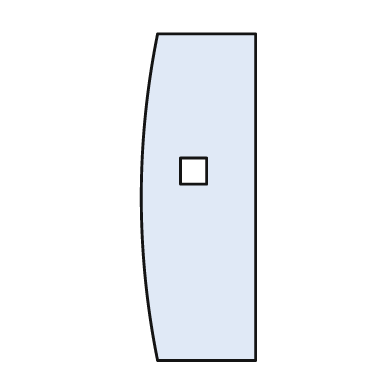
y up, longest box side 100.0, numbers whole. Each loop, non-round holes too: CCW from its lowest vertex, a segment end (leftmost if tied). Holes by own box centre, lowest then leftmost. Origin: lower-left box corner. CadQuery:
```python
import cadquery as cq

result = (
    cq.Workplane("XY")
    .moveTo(5.0, 0.0)
    .lineTo(35.0, 0.0)
    .lineTo(35.0, 100.0)
    .lineTo(5.0, 100.0)
    .threePointArc((0.0, 50.0), (5.0, 0.0))
    .close()
    .moveTo(12.0, 54.0)
    .lineTo(20.0, 54.0)
    .lineTo(20.0, 62.0)
    .lineTo(12.0, 62.0)
    .close()
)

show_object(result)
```